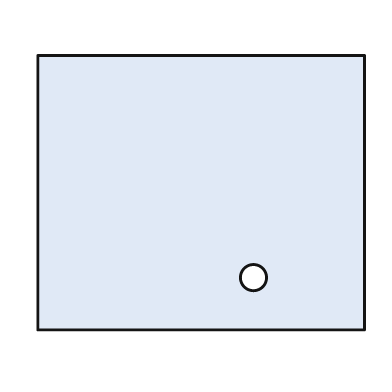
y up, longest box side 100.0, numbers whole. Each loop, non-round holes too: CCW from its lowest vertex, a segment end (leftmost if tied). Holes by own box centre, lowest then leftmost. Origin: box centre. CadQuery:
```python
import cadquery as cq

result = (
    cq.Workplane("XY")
    .moveTo(-50.0, -42.0)
    .lineTo(50.0, -42.0)
    .lineTo(50.0, 42.0)
    .lineTo(-50.0, 42.0)
    .close()
    .moveTo(16.0, -26.0)
    .circle(4.0)
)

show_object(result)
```